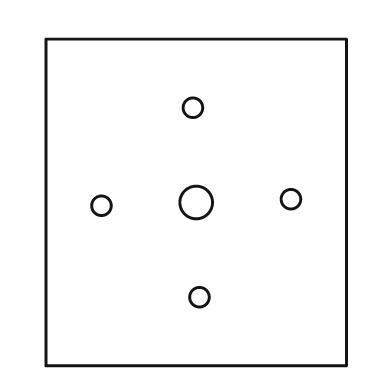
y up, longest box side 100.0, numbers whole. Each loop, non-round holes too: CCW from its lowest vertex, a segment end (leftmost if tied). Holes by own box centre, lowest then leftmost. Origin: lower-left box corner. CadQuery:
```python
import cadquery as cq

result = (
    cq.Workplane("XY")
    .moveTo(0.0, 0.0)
    .lineTo(92.0, 0.0)
    .lineTo(92.0, 100.0)
    .lineTo(0.0, 100.0)
    .close()
    .moveTo(47.0, 21.0)
    .circle(3.0)
    .moveTo(17.0, 49.0)
    .circle(3.0)
    .moveTo(46.0, 50.0)
    .circle(5.0)
    .moveTo(75.0, 51.0)
    .circle(3.0)
    .moveTo(45.0, 79.0)
    .circle(3.0)
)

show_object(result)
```